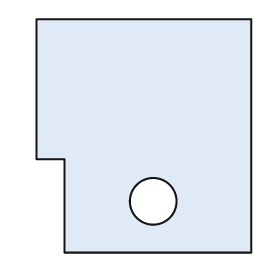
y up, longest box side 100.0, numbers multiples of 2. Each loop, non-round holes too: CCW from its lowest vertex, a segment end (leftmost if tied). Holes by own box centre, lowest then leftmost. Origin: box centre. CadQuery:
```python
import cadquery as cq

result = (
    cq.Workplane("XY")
    .moveTo(-34.0, -50.0)
    .lineTo(46.0, -50.0)
    .lineTo(46.0, 50.0)
    .lineTo(-46.0, 50.0)
    .lineTo(-46.0, -10.0)
    .lineTo(-34.0, -10.0)
    .close()
    .moveTo(4.0, -28.0)
    .circle(10.0)
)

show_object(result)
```